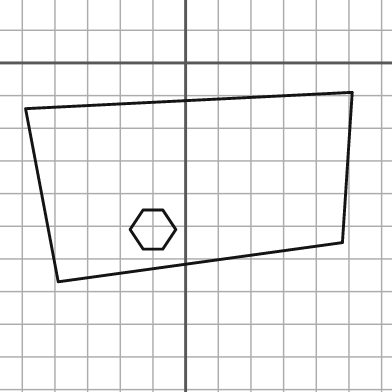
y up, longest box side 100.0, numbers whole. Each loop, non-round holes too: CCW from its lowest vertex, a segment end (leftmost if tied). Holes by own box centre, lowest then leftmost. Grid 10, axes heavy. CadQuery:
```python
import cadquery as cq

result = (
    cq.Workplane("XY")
    .moveTo(-39.0, -67.0)
    .lineTo(48.0, -55.0)
    .lineTo(51.0, -9.0)
    .lineTo(-49.0, -14.0)
    .close()
    .moveTo(-13.0, -57.0)
    .lineTo(-7.0, -57.0)
    .lineTo(-3.0, -51.0)
    .lineTo(-7.0, -45.0)
    .lineTo(-13.0, -45.0)
    .lineTo(-17.0, -51.0)
    .close()
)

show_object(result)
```